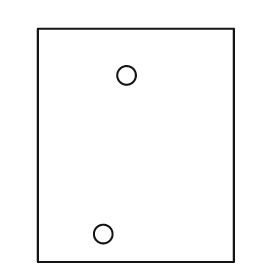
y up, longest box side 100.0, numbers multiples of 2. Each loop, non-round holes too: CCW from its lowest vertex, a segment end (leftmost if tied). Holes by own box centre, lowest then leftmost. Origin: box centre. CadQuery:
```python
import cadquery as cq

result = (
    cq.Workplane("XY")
    .moveTo(-42.0, -50.0)
    .lineTo(42.0, -50.0)
    .lineTo(42.0, 50.0)
    .lineTo(-42.0, 50.0)
    .close()
    .moveTo(-14.0, -38.0)
    .circle(4.0)
    .moveTo(-4.0, 30.0)
    .circle(4.0)
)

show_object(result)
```